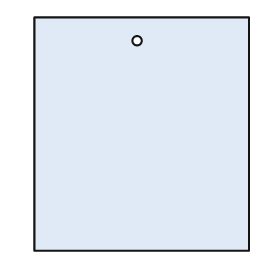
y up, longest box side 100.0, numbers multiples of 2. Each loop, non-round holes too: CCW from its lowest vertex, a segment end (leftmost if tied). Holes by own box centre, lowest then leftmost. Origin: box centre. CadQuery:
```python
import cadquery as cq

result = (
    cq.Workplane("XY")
    .moveTo(-46.0, -50.0)
    .lineTo(46.0, -50.0)
    .lineTo(46.0, 50.0)
    .lineTo(-46.0, 50.0)
    .close()
    .moveTo(-2.0, 40.0)
    .circle(2.0)
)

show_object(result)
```